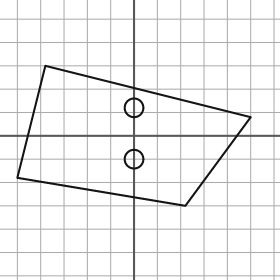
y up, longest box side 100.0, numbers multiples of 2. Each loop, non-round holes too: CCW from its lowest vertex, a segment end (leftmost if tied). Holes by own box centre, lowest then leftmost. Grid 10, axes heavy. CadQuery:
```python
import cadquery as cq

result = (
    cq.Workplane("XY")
    .moveTo(22.0, -30.0)
    .lineTo(50.0, 8.0)
    .lineTo(-38.0, 30.0)
    .lineTo(-50.0, -18.0)
    .close()
    .moveTo(0.0, -10.0)
    .circle(4.0)
    .moveTo(0.0, 12.0)
    .circle(4.0)
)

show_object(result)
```